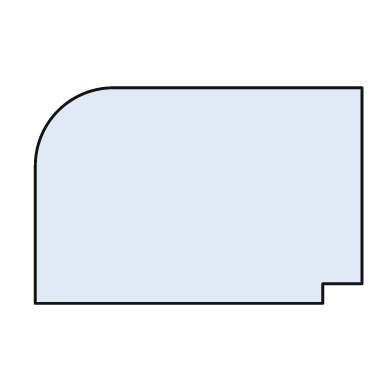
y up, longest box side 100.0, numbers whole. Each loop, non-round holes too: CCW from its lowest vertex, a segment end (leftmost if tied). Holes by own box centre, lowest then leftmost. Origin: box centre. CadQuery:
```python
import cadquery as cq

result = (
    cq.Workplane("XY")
    .moveTo(-50.0, -33.0)
    .lineTo(38.0, -33.0)
    .lineTo(38.0, -27.0)
    .lineTo(50.0, -27.0)
    .lineTo(50.0, 33.0)
    .lineTo(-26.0, 33.0)
    .threePointArc((-43.0, 26.0), (-50.0, 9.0))
    .close()
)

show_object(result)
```